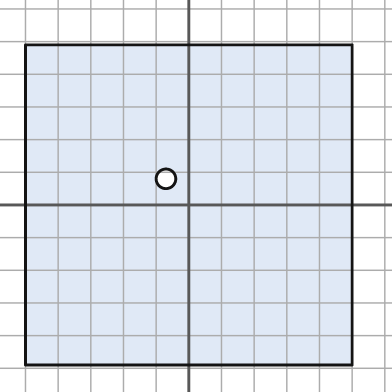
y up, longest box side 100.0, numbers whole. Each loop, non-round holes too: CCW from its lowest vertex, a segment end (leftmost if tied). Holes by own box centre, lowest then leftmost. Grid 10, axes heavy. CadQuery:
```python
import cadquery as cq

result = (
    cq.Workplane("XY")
    .moveTo(-50.0, -49.0)
    .lineTo(50.0, -49.0)
    .lineTo(50.0, 49.0)
    .lineTo(-50.0, 49.0)
    .close()
    .moveTo(-7.0, 8.0)
    .circle(3.0)
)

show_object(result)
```